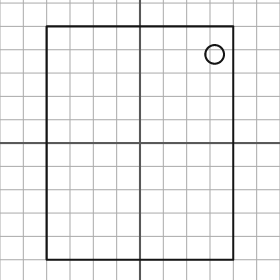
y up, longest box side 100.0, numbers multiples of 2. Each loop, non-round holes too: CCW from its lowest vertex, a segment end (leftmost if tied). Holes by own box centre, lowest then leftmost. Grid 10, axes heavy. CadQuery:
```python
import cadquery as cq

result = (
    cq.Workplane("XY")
    .moveTo(-40.0, -50.0)
    .lineTo(40.0, -50.0)
    .lineTo(40.0, 50.0)
    .lineTo(-40.0, 50.0)
    .close()
    .moveTo(32.0, 38.0)
    .circle(4.0)
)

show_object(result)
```